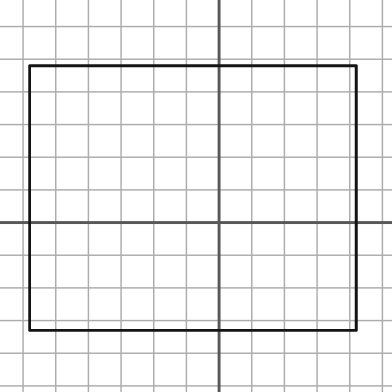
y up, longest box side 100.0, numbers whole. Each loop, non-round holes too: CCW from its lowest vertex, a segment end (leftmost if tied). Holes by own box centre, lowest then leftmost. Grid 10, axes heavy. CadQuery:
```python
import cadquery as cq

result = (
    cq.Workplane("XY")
    .moveTo(-58.0, -33.0)
    .lineTo(42.0, -33.0)
    .lineTo(42.0, 48.0)
    .lineTo(-58.0, 48.0)
    .close()
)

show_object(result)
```